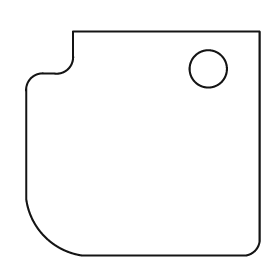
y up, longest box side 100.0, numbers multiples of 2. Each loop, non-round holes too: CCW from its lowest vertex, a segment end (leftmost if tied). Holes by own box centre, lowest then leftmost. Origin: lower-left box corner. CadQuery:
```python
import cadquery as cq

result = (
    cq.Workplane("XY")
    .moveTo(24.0, 0.0)
    .lineTo(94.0, 0.0)
    .threePointArc((98.0, 2.0), (100.0, 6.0))
    .lineTo(100.0, 96.0)
    .lineTo(20.0, 96.0)
    .lineTo(20.0, 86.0)
    .threePointArc((18.0, 80.0), (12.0, 78.0))
    .lineTo(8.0, 78.0)
    .threePointArc((2.0, 76.0), (0.0, 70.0))
    .lineTo(0.0, 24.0)
    .threePointArc((8.0, 8.0), (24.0, 0.0))
    .close()
    .moveTo(78.0, 80.0)
    .circle(8.0)
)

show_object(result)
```